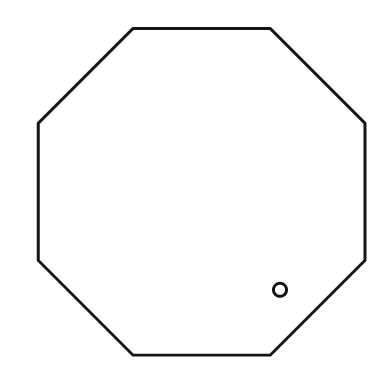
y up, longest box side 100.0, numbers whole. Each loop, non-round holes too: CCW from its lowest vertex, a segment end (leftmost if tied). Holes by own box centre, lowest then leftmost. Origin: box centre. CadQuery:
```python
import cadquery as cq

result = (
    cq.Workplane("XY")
    .moveTo(-21.0, -50.0)
    .lineTo(21.0, -50.0)
    .lineTo(50.0, -21.0)
    .lineTo(50.0, 21.0)
    .lineTo(21.0, 50.0)
    .lineTo(-21.0, 50.0)
    .lineTo(-50.0, 21.0)
    .lineTo(-50.0, -21.0)
    .close()
    .moveTo(24.0, -30.0)
    .circle(2.0)
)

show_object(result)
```